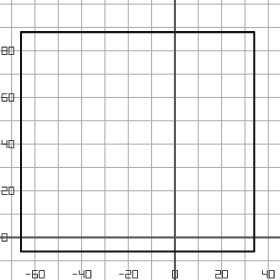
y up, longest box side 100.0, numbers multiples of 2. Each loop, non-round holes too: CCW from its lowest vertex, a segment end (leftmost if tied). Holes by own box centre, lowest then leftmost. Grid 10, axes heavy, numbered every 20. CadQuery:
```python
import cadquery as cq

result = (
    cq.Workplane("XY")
    .moveTo(-66.0, -6.0)
    .lineTo(34.0, -6.0)
    .lineTo(34.0, 88.0)
    .lineTo(-66.0, 88.0)
    .close()
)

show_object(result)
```